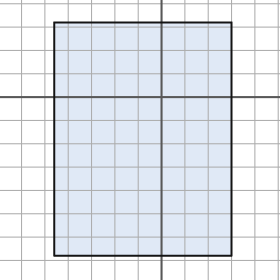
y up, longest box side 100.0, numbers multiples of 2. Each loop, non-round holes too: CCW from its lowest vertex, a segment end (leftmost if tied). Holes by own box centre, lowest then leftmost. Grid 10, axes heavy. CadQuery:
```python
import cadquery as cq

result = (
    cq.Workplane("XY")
    .moveTo(-46.0, -68.0)
    .lineTo(30.0, -68.0)
    .lineTo(30.0, 32.0)
    .lineTo(-46.0, 32.0)
    .close()
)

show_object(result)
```